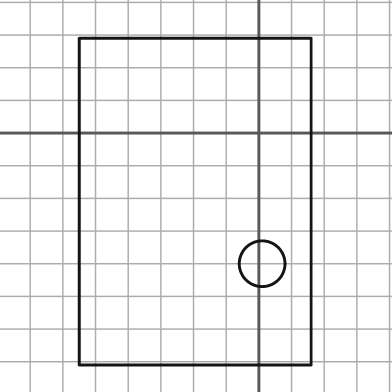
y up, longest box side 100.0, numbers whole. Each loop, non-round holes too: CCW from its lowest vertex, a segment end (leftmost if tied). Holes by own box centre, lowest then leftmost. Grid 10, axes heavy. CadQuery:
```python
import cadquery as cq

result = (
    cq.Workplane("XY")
    .moveTo(-55.0, -71.0)
    .lineTo(16.0, -71.0)
    .lineTo(16.0, 29.0)
    .lineTo(-55.0, 29.0)
    .close()
    .moveTo(1.0, -40.0)
    .circle(7.0)
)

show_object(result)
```